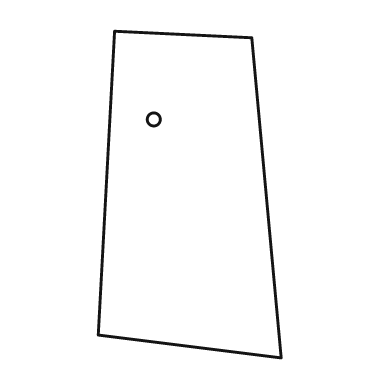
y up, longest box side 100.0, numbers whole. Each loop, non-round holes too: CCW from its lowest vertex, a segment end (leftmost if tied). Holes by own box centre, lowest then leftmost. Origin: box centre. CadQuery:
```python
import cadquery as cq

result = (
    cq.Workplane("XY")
    .moveTo(28.0, -50.0)
    .lineTo(19.0, 48.0)
    .lineTo(-23.0, 50.0)
    .lineTo(-28.0, -43.0)
    .close()
    .moveTo(-11.0, 23.0)
    .circle(2.0)
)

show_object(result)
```